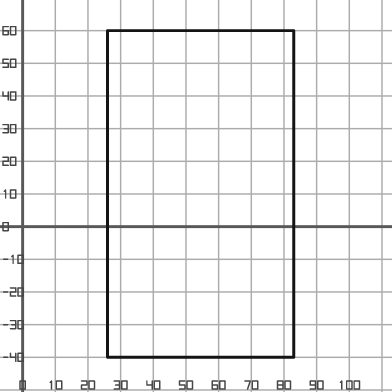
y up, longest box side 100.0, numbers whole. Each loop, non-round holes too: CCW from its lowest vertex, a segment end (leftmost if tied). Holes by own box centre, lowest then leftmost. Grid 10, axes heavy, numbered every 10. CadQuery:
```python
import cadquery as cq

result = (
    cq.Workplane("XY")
    .moveTo(26.0, -40.0)
    .lineTo(83.0, -40.0)
    .lineTo(83.0, 60.0)
    .lineTo(26.0, 60.0)
    .close()
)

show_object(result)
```